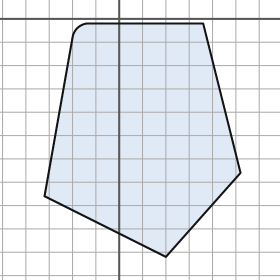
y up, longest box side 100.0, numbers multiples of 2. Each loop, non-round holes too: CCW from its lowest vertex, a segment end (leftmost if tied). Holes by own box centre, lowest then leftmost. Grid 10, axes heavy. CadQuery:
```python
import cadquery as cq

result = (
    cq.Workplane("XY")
    .moveTo(20.0, -102.0)
    .lineTo(52.0, -66.0)
    .lineTo(36.0, -2.0)
    .lineTo(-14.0, -2.0)
    .threePointArc((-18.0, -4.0), (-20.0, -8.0))
    .lineTo(-32.0, -76.0)
    .close()
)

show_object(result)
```